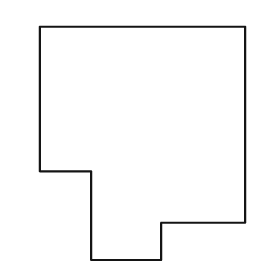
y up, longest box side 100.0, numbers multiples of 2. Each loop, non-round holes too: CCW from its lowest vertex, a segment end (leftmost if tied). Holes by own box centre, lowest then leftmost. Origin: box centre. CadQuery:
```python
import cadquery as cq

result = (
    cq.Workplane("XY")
    .moveTo(-22.0, -50.0)
    .lineTo(8.0, -50.0)
    .lineTo(8.0, -34.0)
    .lineTo(44.0, -34.0)
    .lineTo(44.0, 50.0)
    .lineTo(-44.0, 50.0)
    .lineTo(-44.0, -12.0)
    .lineTo(-22.0, -12.0)
    .close()
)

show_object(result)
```